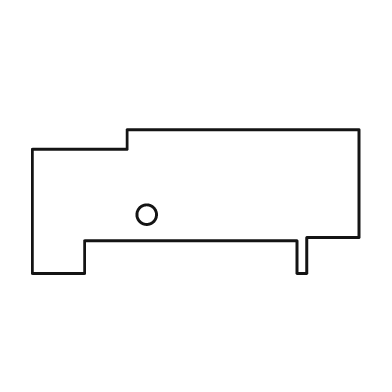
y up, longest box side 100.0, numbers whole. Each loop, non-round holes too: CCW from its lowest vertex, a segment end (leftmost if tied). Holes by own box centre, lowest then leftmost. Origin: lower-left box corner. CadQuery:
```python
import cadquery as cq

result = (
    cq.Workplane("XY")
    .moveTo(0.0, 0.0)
    .lineTo(16.0, 0.0)
    .lineTo(16.0, 10.0)
    .lineTo(81.0, 10.0)
    .lineTo(81.0, 0.0)
    .lineTo(84.0, 0.0)
    .lineTo(84.0, 11.0)
    .lineTo(100.0, 11.0)
    .lineTo(100.0, 44.0)
    .lineTo(29.0, 44.0)
    .lineTo(29.0, 38.0)
    .lineTo(0.0, 38.0)
    .close()
    .moveTo(35.0, 18.0)
    .circle(3.0)
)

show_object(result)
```